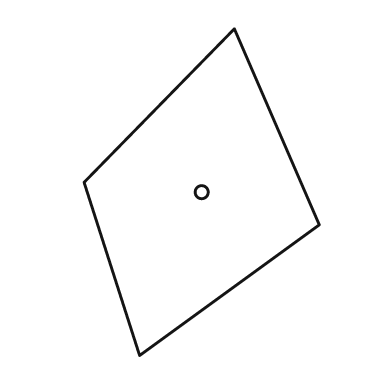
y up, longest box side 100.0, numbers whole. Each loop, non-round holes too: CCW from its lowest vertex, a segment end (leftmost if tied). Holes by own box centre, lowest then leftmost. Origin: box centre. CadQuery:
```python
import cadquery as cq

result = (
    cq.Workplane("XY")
    .moveTo(-19.0, -50.0)
    .lineTo(36.0, -10.0)
    .lineTo(10.0, 50.0)
    .lineTo(-36.0, 3.0)
    .close()
    .moveTo(0.0, 0.0)
    .circle(2.0)
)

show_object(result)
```